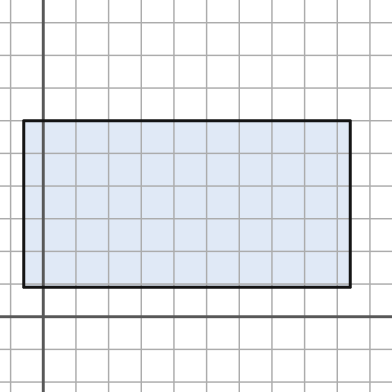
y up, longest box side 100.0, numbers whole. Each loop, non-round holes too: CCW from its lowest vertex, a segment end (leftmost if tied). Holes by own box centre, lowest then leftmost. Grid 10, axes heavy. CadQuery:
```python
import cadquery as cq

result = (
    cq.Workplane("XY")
    .moveTo(-6.0, 9.0)
    .lineTo(94.0, 9.0)
    .lineTo(94.0, 60.0)
    .lineTo(-6.0, 60.0)
    .close()
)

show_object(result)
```